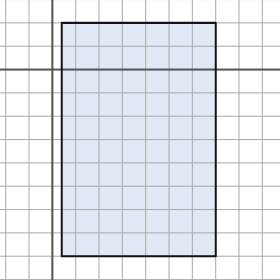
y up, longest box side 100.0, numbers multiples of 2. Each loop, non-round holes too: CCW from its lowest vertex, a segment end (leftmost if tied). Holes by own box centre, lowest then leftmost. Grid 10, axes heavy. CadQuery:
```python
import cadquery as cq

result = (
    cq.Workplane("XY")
    .moveTo(4.0, -80.0)
    .lineTo(70.0, -80.0)
    .lineTo(70.0, 20.0)
    .lineTo(4.0, 20.0)
    .close()
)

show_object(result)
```